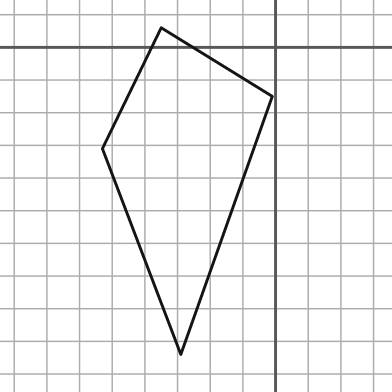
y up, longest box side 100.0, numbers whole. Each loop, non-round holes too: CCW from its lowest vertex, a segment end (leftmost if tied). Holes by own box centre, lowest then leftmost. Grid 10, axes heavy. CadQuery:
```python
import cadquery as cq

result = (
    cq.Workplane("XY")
    .moveTo(-29.0, -94.0)
    .lineTo(-1.0, -15.0)
    .lineTo(-35.0, 6.0)
    .lineTo(-53.0, -31.0)
    .close()
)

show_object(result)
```